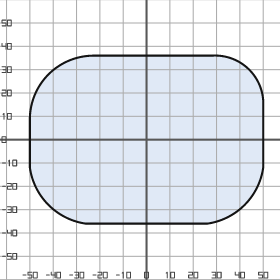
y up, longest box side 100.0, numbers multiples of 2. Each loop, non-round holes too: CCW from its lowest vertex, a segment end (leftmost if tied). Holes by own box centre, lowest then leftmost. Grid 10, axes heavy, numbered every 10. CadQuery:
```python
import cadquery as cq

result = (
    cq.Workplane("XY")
    .moveTo(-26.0, -36.0)
    .lineTo(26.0, -36.0)
    .threePointArc((42.0, -28.0), (50.0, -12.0))
    .lineTo(50.0, 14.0)
    .threePointArc((44.0, 30.0), (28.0, 36.0))
    .lineTo(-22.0, 36.0)
    .threePointArc((-42.0, 28.0), (-50.0, 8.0))
    .lineTo(-50.0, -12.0)
    .threePointArc((-42.0, -28.0), (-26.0, -36.0))
    .close()
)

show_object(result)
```